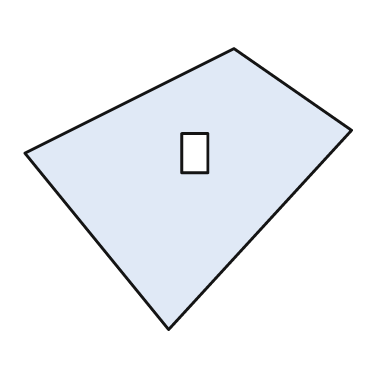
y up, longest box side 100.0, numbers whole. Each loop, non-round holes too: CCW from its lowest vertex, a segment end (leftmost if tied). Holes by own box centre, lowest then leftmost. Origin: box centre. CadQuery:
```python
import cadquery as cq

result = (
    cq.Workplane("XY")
    .moveTo(-6.0, -43.0)
    .lineTo(50.0, 18.0)
    .lineTo(14.0, 43.0)
    .lineTo(-50.0, 11.0)
    .close()
    .moveTo(-2.0, 5.0)
    .lineTo(6.0, 5.0)
    .lineTo(6.0, 17.0)
    .lineTo(-2.0, 17.0)
    .close()
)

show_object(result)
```